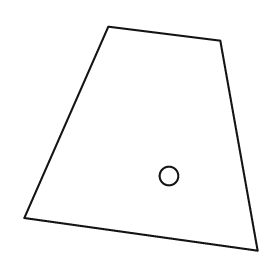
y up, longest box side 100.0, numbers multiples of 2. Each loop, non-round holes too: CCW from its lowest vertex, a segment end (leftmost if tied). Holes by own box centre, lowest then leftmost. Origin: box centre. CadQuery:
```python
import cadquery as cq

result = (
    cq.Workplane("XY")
    .moveTo(50.0, -48.0)
    .lineTo(34.0, 42.0)
    .lineTo(-14.0, 48.0)
    .lineTo(-50.0, -34.0)
    .close()
    .moveTo(12.0, -16.0)
    .circle(4.0)
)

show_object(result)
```